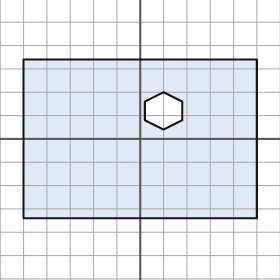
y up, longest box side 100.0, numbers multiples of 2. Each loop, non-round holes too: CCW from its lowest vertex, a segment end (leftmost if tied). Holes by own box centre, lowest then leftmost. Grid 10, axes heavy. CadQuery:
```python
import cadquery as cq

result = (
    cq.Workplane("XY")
    .moveTo(-50.0, -34.0)
    .lineTo(50.0, -34.0)
    .lineTo(50.0, 34.0)
    .lineTo(-50.0, 34.0)
    .close()
    .moveTo(10.0, 4.0)
    .lineTo(18.0, 8.0)
    .lineTo(18.0, 16.0)
    .lineTo(10.0, 20.0)
    .lineTo(2.0, 16.0)
    .lineTo(2.0, 8.0)
    .close()
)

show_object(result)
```